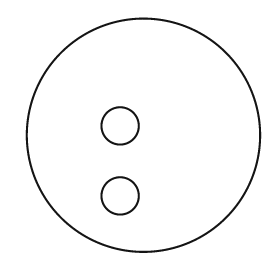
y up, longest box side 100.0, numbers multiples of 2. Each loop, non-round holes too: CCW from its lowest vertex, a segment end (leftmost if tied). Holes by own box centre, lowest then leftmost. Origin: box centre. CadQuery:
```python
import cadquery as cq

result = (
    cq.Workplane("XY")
    .moveTo(0.0, 0.0)
    .circle(50.0)
    .moveTo(-10.0, -26.0)
    .circle(8.0)
    .moveTo(-10.0, 4.0)
    .circle(8.0)
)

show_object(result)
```